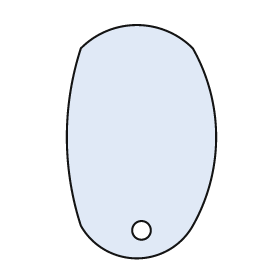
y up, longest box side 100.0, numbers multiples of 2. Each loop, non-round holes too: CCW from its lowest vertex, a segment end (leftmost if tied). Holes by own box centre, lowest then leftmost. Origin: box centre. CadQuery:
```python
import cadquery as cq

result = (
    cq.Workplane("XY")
    .moveTo(-26.0, -36.0)
    .threePointArc((-2.0, -50.0), (22.0, -36.0))
    .threePointArc((32.0, 2.0), (22.0, 40.0))
    .threePointArc((-2.0, 50.0), (-26.0, 40.0))
    .threePointArc((-32.0, 2.0), (-26.0, -36.0))
    .close()
    .moveTo(0.0, -38.0)
    .circle(4.0)
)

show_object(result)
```